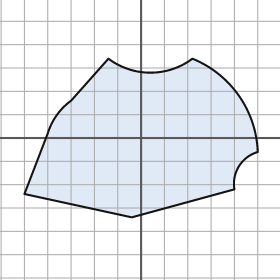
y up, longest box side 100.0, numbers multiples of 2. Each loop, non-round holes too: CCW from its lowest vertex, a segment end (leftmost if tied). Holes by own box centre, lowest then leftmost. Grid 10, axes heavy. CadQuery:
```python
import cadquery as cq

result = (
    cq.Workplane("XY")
    .moveTo(-4.0, -34.0)
    .lineTo(40.0, -22.0)
    .threePointArc((42.0, -12.0), (50.0, -6.0))
    .threePointArc((42.0, 18.0), (22.0, 34.0))
    .threePointArc((4.0, 28.0), (-14.0, 34.0))
    .lineTo(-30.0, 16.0)
    .threePointArc((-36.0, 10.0), (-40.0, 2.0))
    .lineTo(-50.0, -24.0)
    .close()
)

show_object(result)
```